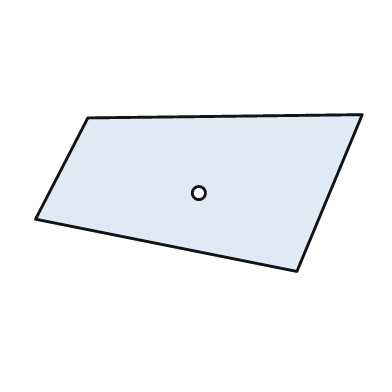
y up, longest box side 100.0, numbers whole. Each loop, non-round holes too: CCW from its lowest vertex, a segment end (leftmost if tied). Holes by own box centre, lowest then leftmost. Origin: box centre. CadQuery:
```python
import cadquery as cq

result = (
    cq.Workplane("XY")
    .moveTo(30.0, -24.0)
    .lineTo(50.0, 24.0)
    .lineTo(-34.0, 23.0)
    .lineTo(-50.0, -8.0)
    .close()
    .moveTo(0.0, 0.0)
    .circle(2.0)
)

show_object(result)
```